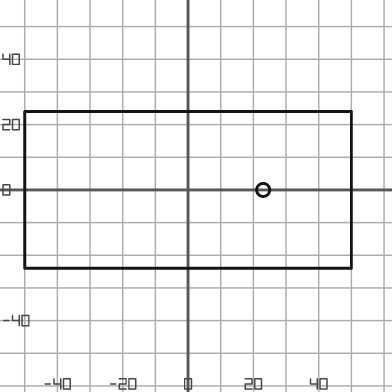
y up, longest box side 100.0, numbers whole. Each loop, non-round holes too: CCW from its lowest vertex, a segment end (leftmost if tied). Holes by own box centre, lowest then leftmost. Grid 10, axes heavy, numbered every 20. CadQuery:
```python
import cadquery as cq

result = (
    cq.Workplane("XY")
    .moveTo(-50.0, -24.0)
    .lineTo(50.0, -24.0)
    .lineTo(50.0, 24.0)
    .lineTo(-50.0, 24.0)
    .close()
    .moveTo(23.0, 0.0)
    .circle(2.0)
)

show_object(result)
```